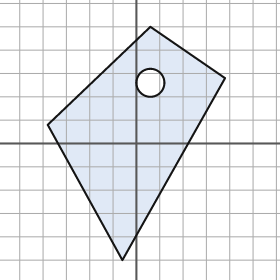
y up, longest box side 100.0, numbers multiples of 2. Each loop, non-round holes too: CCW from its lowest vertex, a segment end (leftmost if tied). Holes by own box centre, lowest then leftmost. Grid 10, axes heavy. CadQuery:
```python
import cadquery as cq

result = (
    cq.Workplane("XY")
    .moveTo(-6.0, -50.0)
    .lineTo(38.0, 28.0)
    .lineTo(6.0, 50.0)
    .lineTo(-38.0, 8.0)
    .close()
    .moveTo(6.0, 26.0)
    .circle(6.0)
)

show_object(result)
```